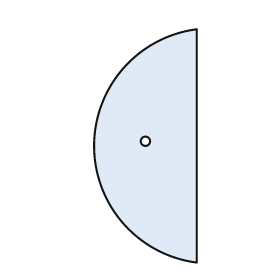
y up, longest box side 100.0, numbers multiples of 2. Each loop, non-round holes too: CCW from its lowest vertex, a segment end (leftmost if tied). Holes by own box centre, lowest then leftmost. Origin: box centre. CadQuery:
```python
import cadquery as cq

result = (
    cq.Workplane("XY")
    .moveTo(22.0, -50.0)
    .lineTo(22.0, 50.0)
    .threePointArc((-22.0, 0.0), (22.0, -50.0))
    .close()
    .moveTo(0.0, 2.0)
    .circle(2.0)
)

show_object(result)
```